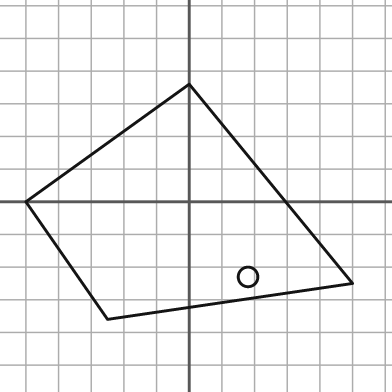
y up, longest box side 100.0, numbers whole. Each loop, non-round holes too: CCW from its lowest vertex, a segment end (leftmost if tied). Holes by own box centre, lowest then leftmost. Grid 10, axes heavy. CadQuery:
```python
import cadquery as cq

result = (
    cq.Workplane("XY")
    .moveTo(-25.0, -36.0)
    .lineTo(50.0, -25.0)
    .lineTo(0.0, 36.0)
    .lineTo(-50.0, 0.0)
    .close()
    .moveTo(18.0, -23.0)
    .circle(3.0)
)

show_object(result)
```